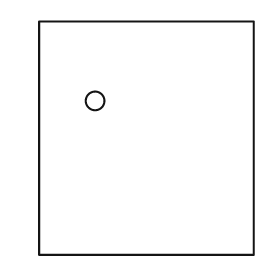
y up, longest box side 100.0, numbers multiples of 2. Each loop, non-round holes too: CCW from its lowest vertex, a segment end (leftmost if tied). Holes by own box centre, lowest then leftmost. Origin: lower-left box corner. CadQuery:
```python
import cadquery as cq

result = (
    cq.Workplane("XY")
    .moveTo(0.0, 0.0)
    .lineTo(92.0, 0.0)
    .lineTo(92.0, 100.0)
    .lineTo(0.0, 100.0)
    .close()
    .moveTo(24.0, 66.0)
    .circle(4.0)
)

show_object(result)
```